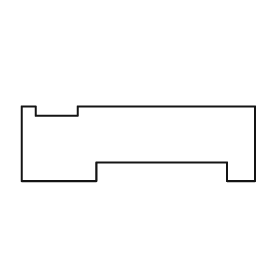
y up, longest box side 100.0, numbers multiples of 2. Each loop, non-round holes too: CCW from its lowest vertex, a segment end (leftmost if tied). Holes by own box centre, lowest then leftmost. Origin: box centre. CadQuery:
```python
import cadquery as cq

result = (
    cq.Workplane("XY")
    .moveTo(-50.0, -16.0)
    .lineTo(-18.0, -16.0)
    .lineTo(-18.0, -8.0)
    .lineTo(38.0, -8.0)
    .lineTo(38.0, -16.0)
    .lineTo(50.0, -16.0)
    .lineTo(50.0, 16.0)
    .lineTo(-26.0, 16.0)
    .lineTo(-26.0, 12.0)
    .lineTo(-44.0, 12.0)
    .lineTo(-44.0, 16.0)
    .lineTo(-50.0, 16.0)
    .close()
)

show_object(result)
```